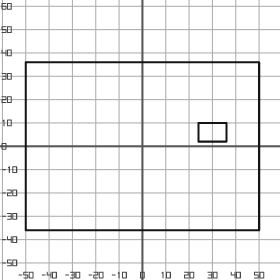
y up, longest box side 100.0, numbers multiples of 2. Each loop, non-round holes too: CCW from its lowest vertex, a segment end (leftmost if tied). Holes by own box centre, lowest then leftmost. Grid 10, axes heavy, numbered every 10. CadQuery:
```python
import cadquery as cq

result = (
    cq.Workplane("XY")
    .moveTo(-50.0, -36.0)
    .lineTo(50.0, -36.0)
    .lineTo(50.0, 36.0)
    .lineTo(-50.0, 36.0)
    .close()
    .moveTo(24.0, 2.0)
    .lineTo(36.0, 2.0)
    .lineTo(36.0, 10.0)
    .lineTo(24.0, 10.0)
    .close()
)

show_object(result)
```